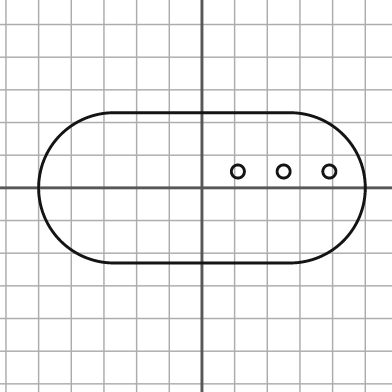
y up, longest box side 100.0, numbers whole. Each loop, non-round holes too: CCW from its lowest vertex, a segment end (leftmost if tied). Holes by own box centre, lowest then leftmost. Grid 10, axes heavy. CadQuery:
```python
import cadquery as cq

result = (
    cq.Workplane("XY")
    .moveTo(-27.0, -23.0)
    .lineTo(27.0, -23.0)
    .threePointArc((50.0, 0.0), (27.0, 23.0))
    .lineTo(-27.0, 23.0)
    .threePointArc((-50.0, 0.0), (-27.0, -23.0))
    .close()
    .moveTo(11.0, 5.0)
    .circle(2.0)
    .moveTo(25.0, 5.0)
    .circle(2.0)
    .moveTo(39.0, 5.0)
    .circle(2.0)
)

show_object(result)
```